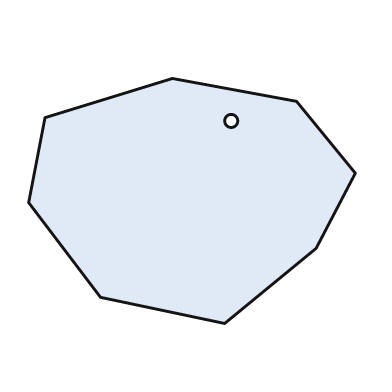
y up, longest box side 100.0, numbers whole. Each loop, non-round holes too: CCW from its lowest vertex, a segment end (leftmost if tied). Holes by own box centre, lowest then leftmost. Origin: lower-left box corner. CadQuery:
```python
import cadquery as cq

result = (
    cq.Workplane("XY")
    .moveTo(60.0, 0.0)
    .lineTo(88.0, 23.0)
    .lineTo(100.0, 46.0)
    .lineTo(82.0, 68.0)
    .lineTo(44.0, 75.0)
    .lineTo(5.0, 63.0)
    .lineTo(0.0, 37.0)
    .lineTo(22.0, 8.0)
    .close()
    .moveTo(62.0, 62.0)
    .circle(2.0)
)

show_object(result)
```